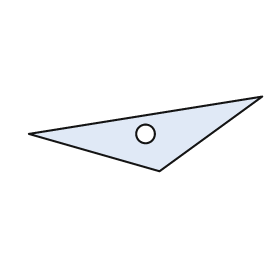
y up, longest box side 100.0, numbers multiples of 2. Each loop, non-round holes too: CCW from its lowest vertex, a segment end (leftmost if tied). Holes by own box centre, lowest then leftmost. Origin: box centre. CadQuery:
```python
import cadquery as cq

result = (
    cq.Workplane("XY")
    .moveTo(6.0, -16.0)
    .lineTo(50.0, 16.0)
    .lineTo(-50.0, 0.0)
    .close()
    .moveTo(0.0, 0.0)
    .circle(4.0)
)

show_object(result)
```